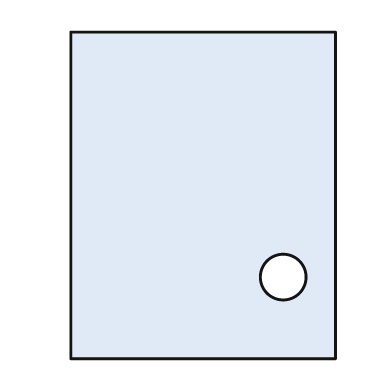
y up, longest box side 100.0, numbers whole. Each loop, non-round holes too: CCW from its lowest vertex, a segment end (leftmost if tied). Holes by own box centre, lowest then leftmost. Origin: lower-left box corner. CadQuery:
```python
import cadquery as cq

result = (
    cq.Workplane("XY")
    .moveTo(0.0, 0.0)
    .lineTo(81.0, 0.0)
    .lineTo(81.0, 100.0)
    .lineTo(0.0, 100.0)
    .close()
    .moveTo(65.0, 25.0)
    .circle(7.0)
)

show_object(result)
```